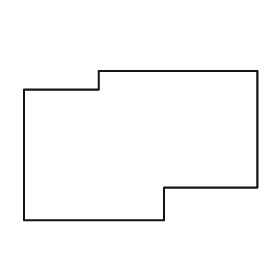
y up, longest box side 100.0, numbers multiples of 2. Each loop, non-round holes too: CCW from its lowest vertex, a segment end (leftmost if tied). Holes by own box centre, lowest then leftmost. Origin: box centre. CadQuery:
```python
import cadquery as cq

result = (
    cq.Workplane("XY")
    .moveTo(-50.0, -32.0)
    .lineTo(10.0, -32.0)
    .lineTo(10.0, -18.0)
    .lineTo(50.0, -18.0)
    .lineTo(50.0, 32.0)
    .lineTo(-18.0, 32.0)
    .lineTo(-18.0, 24.0)
    .lineTo(-50.0, 24.0)
    .close()
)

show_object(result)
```